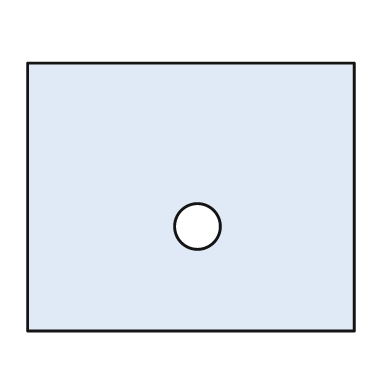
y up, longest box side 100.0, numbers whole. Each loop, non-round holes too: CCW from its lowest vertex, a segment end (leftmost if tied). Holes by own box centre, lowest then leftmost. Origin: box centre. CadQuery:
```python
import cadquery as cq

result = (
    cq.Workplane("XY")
    .moveTo(-50.0, -41.0)
    .lineTo(50.0, -41.0)
    .lineTo(50.0, 41.0)
    .lineTo(-50.0, 41.0)
    .close()
    .moveTo(2.0, -9.0)
    .circle(7.0)
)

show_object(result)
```